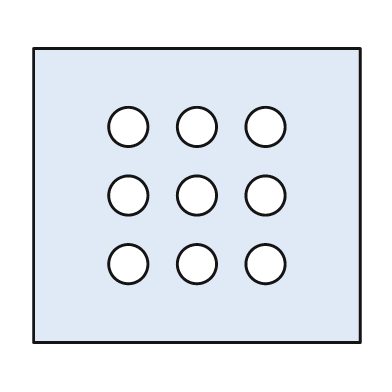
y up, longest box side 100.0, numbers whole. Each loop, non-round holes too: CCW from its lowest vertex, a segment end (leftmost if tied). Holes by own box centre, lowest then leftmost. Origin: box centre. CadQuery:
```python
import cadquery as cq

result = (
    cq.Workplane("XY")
    .moveTo(-50.0, -45.0)
    .lineTo(50.0, -45.0)
    .lineTo(50.0, 45.0)
    .lineTo(-50.0, 45.0)
    .close()
    .moveTo(-21.0, -21.0)
    .circle(6.0)
    .moveTo(0.0, -21.0)
    .circle(6.0)
    .moveTo(21.0, -21.0)
    .circle(6.0)
    .moveTo(-21.0, 0.0)
    .circle(6.0)
    .moveTo(0.0, 0.0)
    .circle(6.0)
    .moveTo(21.0, 0.0)
    .circle(6.0)
    .moveTo(-21.0, 21.0)
    .circle(6.0)
    .moveTo(0.0, 21.0)
    .circle(6.0)
    .moveTo(21.0, 21.0)
    .circle(6.0)
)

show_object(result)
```